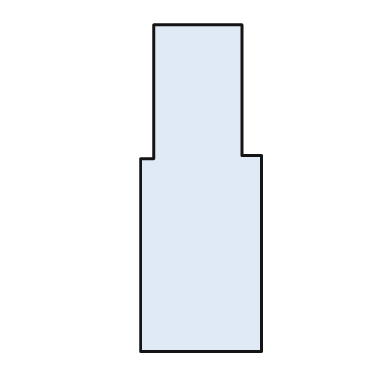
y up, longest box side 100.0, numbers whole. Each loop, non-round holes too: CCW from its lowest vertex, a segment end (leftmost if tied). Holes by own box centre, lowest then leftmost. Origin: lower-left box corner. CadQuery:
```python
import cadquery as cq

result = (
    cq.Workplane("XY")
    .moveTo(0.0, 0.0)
    .lineTo(37.0, 0.0)
    .lineTo(37.0, 60.0)
    .lineTo(31.0, 60.0)
    .lineTo(31.0, 100.0)
    .lineTo(4.0, 100.0)
    .lineTo(4.0, 59.0)
    .lineTo(0.0, 59.0)
    .close()
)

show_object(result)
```